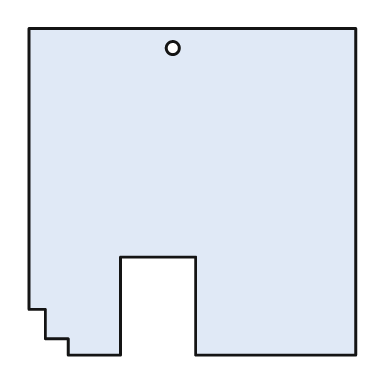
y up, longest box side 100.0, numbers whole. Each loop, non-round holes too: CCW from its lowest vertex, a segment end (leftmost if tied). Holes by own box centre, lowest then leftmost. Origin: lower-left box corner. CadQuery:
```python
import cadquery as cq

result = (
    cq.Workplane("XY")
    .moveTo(12.0, 0.0)
    .lineTo(28.0, 0.0)
    .lineTo(28.0, 30.0)
    .lineTo(51.0, 30.0)
    .lineTo(51.0, 0.0)
    .lineTo(100.0, 0.0)
    .lineTo(100.0, 100.0)
    .lineTo(0.0, 100.0)
    .lineTo(0.0, 14.0)
    .lineTo(5.0, 14.0)
    .lineTo(5.0, 5.0)
    .lineTo(12.0, 5.0)
    .close()
    .moveTo(44.0, 94.0)
    .circle(2.0)
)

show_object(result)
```